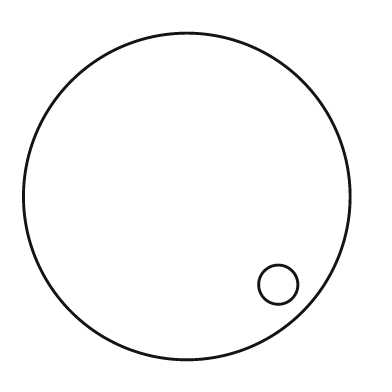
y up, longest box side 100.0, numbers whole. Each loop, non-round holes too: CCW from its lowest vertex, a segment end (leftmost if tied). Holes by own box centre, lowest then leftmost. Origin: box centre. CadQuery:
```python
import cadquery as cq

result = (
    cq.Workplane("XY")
    .moveTo(0.0, 0.0)
    .circle(50.0)
    .moveTo(28.0, -27.0)
    .circle(6.0)
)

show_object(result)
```